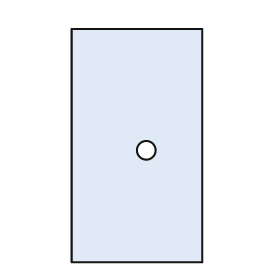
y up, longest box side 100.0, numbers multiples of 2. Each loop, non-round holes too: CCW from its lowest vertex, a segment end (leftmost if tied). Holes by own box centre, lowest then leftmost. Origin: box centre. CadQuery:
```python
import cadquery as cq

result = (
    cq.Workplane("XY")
    .moveTo(-28.0, -50.0)
    .lineTo(28.0, -50.0)
    .lineTo(28.0, 50.0)
    .lineTo(-28.0, 50.0)
    .close()
    .moveTo(4.0, -2.0)
    .circle(4.0)
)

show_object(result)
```